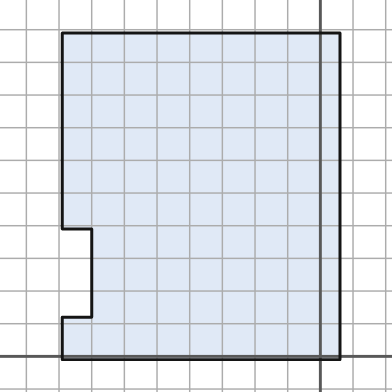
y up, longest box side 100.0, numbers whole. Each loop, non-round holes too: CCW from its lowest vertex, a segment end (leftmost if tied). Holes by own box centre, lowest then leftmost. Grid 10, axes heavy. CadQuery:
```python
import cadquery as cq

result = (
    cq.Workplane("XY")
    .moveTo(-79.0, -1.0)
    .lineTo(6.0, -1.0)
    .lineTo(6.0, 99.0)
    .lineTo(-79.0, 99.0)
    .lineTo(-79.0, 39.0)
    .lineTo(-70.0, 39.0)
    .lineTo(-70.0, 12.0)
    .lineTo(-79.0, 12.0)
    .close()
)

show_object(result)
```